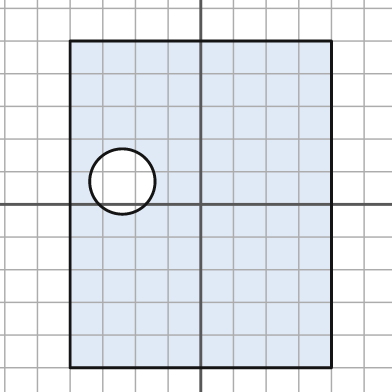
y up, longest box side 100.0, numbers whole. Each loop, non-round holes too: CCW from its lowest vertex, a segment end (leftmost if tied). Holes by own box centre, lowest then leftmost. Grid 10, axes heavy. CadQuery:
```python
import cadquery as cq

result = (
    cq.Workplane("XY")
    .moveTo(-40.0, -50.0)
    .lineTo(40.0, -50.0)
    .lineTo(40.0, 50.0)
    .lineTo(-40.0, 50.0)
    .close()
    .moveTo(-24.0, 7.0)
    .circle(10.0)
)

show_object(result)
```